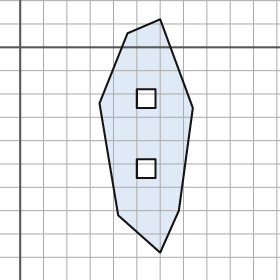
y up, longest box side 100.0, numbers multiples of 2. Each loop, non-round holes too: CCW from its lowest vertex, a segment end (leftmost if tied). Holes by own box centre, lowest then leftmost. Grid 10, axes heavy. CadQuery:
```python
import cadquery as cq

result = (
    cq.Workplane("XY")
    .moveTo(60.0, -88.0)
    .lineTo(68.0, -70.0)
    .lineTo(74.0, -26.0)
    .lineTo(60.0, 12.0)
    .lineTo(46.0, 6.0)
    .lineTo(34.0, -24.0)
    .lineTo(42.0, -72.0)
    .close()
    .moveTo(50.0, -56.0)
    .lineTo(58.0, -56.0)
    .lineTo(58.0, -48.0)
    .lineTo(50.0, -48.0)
    .close()
    .moveTo(50.0, -26.0)
    .lineTo(58.0, -26.0)
    .lineTo(58.0, -18.0)
    .lineTo(50.0, -18.0)
    .close()
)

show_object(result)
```